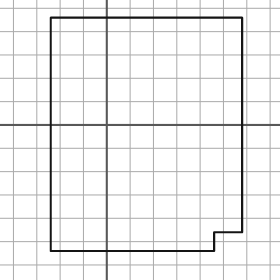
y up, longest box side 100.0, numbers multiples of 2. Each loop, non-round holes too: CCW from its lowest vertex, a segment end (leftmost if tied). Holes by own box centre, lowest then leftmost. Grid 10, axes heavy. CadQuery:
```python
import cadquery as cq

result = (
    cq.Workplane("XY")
    .moveTo(-24.0, -54.0)
    .lineTo(46.0, -54.0)
    .lineTo(46.0, -46.0)
    .lineTo(58.0, -46.0)
    .lineTo(58.0, 46.0)
    .lineTo(-24.0, 46.0)
    .close()
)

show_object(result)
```